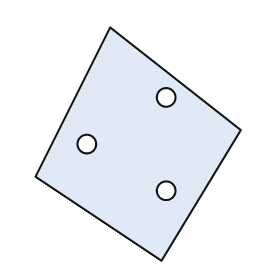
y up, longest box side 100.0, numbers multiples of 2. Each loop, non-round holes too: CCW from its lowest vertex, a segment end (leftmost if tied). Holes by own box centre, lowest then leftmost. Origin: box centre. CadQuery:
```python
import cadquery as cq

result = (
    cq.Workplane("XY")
    .moveTo(10.0, -50.0)
    .lineTo(44.0, 6.0)
    .lineTo(-12.0, 50.0)
    .lineTo(-44.0, -14.0)
    .close()
    .moveTo(12.0, -20.0)
    .circle(4.0)
    .moveTo(-22.0, 0.0)
    .circle(4.0)
    .moveTo(12.0, 20.0)
    .circle(4.0)
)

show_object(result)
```